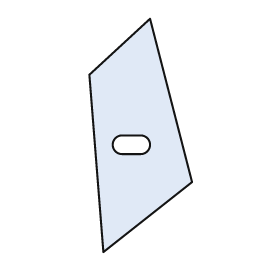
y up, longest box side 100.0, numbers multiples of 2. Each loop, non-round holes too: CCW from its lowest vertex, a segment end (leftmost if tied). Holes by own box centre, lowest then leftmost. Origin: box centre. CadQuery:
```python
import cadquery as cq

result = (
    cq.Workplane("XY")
    .moveTo(-16.0, -50.0)
    .lineTo(22.0, -20.0)
    .lineTo(4.0, 50.0)
    .lineTo(-22.0, 26.0)
    .close()
    .moveTo(-8.0, -8.0)
    .lineTo(0.0, -8.0)
    .threePointArc((4.0, -4.0), (0.0, 0.0))
    .lineTo(-8.0, 0.0)
    .threePointArc((-12.0, -4.0), (-8.0, -8.0))
    .close()
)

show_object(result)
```